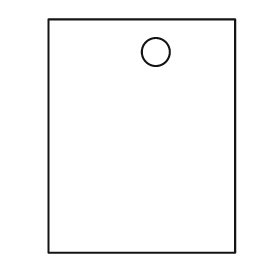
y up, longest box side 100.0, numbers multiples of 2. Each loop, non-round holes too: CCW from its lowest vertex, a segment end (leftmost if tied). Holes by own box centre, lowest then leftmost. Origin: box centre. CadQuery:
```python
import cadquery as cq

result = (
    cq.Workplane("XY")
    .moveTo(-40.0, -50.0)
    .lineTo(40.0, -50.0)
    .lineTo(40.0, 50.0)
    .lineTo(-40.0, 50.0)
    .close()
    .moveTo(6.0, 36.0)
    .circle(6.0)
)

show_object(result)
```